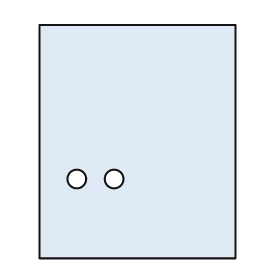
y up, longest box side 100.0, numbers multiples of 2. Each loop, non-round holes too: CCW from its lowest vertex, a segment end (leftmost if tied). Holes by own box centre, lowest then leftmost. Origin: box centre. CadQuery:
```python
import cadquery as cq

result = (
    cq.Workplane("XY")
    .moveTo(-42.0, -50.0)
    .lineTo(42.0, -50.0)
    .lineTo(42.0, 50.0)
    .lineTo(-42.0, 50.0)
    .close()
    .moveTo(-26.0, -16.0)
    .circle(4.0)
    .moveTo(-10.0, -16.0)
    .circle(4.0)
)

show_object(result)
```